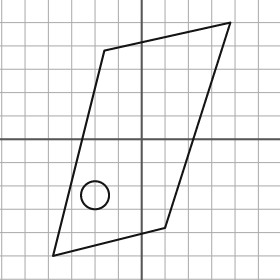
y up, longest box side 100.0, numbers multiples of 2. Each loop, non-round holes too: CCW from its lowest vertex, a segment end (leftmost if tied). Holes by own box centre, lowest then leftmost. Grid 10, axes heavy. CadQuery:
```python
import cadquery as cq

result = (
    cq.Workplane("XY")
    .moveTo(-38.0, -50.0)
    .lineTo(10.0, -38.0)
    .lineTo(38.0, 50.0)
    .lineTo(-16.0, 38.0)
    .close()
    .moveTo(-20.0, -24.0)
    .circle(6.0)
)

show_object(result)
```